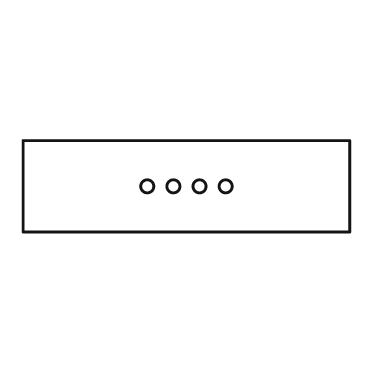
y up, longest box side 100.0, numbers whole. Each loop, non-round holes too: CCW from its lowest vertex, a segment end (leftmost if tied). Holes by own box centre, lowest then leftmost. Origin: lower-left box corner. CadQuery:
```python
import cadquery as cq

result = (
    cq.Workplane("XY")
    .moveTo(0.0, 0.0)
    .lineTo(100.0, 0.0)
    .lineTo(100.0, 28.0)
    .lineTo(0.0, 28.0)
    .close()
    .moveTo(38.0, 14.0)
    .circle(2.0)
    .moveTo(46.0, 14.0)
    .circle(2.0)
    .moveTo(54.0, 14.0)
    .circle(2.0)
    .moveTo(62.0, 14.0)
    .circle(2.0)
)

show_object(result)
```